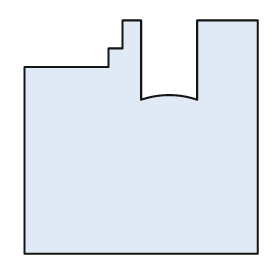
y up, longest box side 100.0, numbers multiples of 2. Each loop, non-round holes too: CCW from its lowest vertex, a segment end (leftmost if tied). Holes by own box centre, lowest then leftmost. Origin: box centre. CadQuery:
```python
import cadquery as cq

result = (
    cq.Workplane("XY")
    .moveTo(-50.0, -50.0)
    .lineTo(50.0, -50.0)
    .lineTo(50.0, 50.0)
    .lineTo(24.0, 50.0)
    .lineTo(24.0, 16.0)
    .threePointArc((12.0, 18.0), (0.0, 16.0))
    .lineTo(0.0, 50.0)
    .lineTo(-8.0, 50.0)
    .lineTo(-8.0, 38.0)
    .lineTo(-14.0, 38.0)
    .lineTo(-14.0, 30.0)
    .lineTo(-50.0, 30.0)
    .close()
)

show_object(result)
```